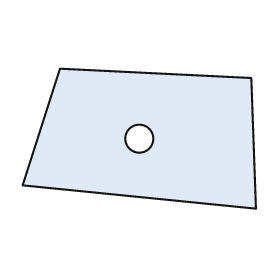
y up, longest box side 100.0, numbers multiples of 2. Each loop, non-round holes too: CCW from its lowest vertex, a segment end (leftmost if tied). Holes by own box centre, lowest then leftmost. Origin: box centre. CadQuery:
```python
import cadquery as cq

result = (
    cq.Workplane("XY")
    .moveTo(50.0, -30.0)
    .lineTo(48.0, 26.0)
    .lineTo(-34.0, 30.0)
    .lineTo(-50.0, -20.0)
    .close()
    .moveTo(0.0, 0.0)
    .circle(6.0)
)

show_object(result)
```